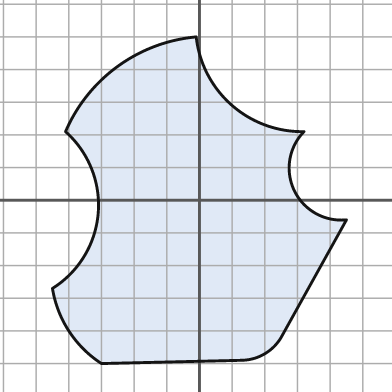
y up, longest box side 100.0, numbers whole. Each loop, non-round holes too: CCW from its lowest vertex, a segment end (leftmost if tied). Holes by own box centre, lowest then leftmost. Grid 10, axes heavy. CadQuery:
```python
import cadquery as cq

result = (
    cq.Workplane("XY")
    .moveTo(-30.0, -50.0)
    .lineTo(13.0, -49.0)
    .threePointArc((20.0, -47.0), (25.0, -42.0))
    .lineTo(45.0, -6.0)
    .threePointArc((29.0, 3.0), (32.0, 21.0))
    .threePointArc((10.0, 29.0), (-1.0, 50.0))
    .threePointArc((-25.0, 41.0), (-41.0, 21.0))
    .threePointArc((-31.0, -4.0), (-45.0, -27.0))
    .threePointArc((-40.0, -40.0), (-30.0, -50.0))
    .close()
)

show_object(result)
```